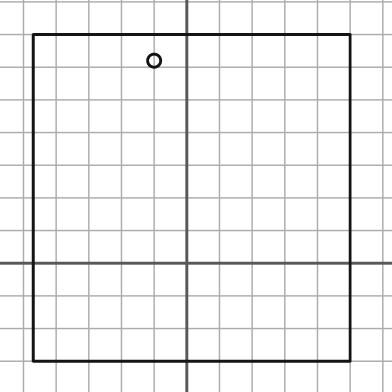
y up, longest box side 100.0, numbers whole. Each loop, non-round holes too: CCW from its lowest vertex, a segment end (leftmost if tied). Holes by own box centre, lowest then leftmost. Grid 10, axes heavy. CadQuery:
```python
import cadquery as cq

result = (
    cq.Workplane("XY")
    .moveTo(-47.0, -30.0)
    .lineTo(50.0, -30.0)
    .lineTo(50.0, 70.0)
    .lineTo(-47.0, 70.0)
    .close()
    .moveTo(-10.0, 62.0)
    .circle(2.0)
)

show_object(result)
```